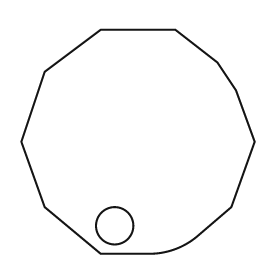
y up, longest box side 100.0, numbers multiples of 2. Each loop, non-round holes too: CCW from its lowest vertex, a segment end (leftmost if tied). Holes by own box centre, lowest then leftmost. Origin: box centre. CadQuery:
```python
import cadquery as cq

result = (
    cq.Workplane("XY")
    .moveTo(-16.0, -48.0)
    .lineTo(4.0, -48.0)
    .threePointArc((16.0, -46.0), (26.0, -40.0))
    .lineTo(40.0, -28.0)
    .lineTo(50.0, 0.0)
    .lineTo(42.0, 22.0)
    .lineTo(34.0, 34.0)
    .lineTo(16.0, 48.0)
    .lineTo(-16.0, 48.0)
    .lineTo(-40.0, 30.0)
    .lineTo(-50.0, 0.0)
    .lineTo(-40.0, -28.0)
    .close()
    .moveTo(-10.0, -36.0)
    .circle(8.0)
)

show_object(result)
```